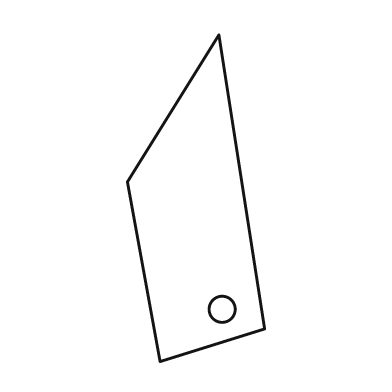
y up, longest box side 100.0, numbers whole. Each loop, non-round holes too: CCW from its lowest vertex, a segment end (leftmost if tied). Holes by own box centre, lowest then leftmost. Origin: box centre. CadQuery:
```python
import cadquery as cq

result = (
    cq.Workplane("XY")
    .moveTo(-11.0, -50.0)
    .lineTo(21.0, -40.0)
    .lineTo(7.0, 50.0)
    .lineTo(-21.0, 5.0)
    .close()
    .moveTo(8.0, -34.0)
    .circle(4.0)
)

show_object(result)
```